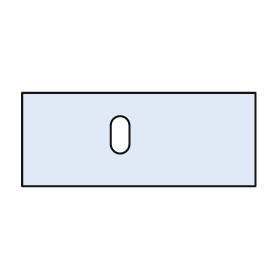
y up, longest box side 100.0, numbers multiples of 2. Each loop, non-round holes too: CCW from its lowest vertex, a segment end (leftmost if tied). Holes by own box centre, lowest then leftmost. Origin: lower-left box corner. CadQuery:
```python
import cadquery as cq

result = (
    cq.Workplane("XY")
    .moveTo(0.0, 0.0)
    .lineTo(100.0, 0.0)
    .lineTo(100.0, 40.0)
    .lineTo(0.0, 40.0)
    .close()
    .moveTo(38.0, 18.0)
    .threePointArc((42.0, 14.0), (46.0, 18.0))
    .lineTo(46.0, 26.0)
    .threePointArc((42.0, 30.0), (38.0, 26.0))
    .close()
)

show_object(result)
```